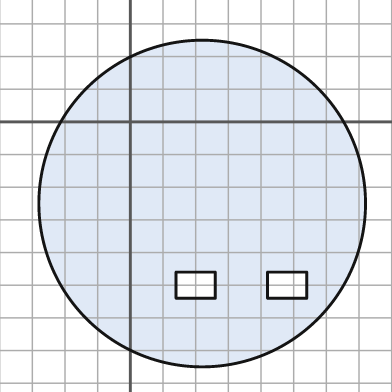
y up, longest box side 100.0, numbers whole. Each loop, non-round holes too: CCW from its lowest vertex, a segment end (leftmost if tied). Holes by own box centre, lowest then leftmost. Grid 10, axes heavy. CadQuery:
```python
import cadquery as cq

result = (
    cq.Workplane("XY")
    .moveTo(22.0, -25.0)
    .circle(50.0)
    .moveTo(14.0, -54.0)
    .lineTo(26.0, -54.0)
    .lineTo(26.0, -46.0)
    .lineTo(14.0, -46.0)
    .close()
    .moveTo(42.0, -54.0)
    .lineTo(54.0, -54.0)
    .lineTo(54.0, -46.0)
    .lineTo(42.0, -46.0)
    .close()
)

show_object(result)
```